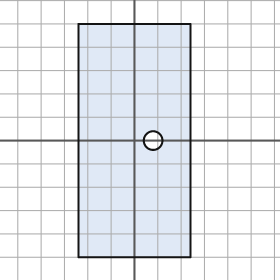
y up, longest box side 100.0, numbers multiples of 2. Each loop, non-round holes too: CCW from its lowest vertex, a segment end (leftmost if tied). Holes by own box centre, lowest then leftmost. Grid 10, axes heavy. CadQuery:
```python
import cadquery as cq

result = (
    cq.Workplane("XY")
    .moveTo(-24.0, -50.0)
    .lineTo(24.0, -50.0)
    .lineTo(24.0, 50.0)
    .lineTo(-24.0, 50.0)
    .close()
    .moveTo(8.0, 0.0)
    .circle(4.0)
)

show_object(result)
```